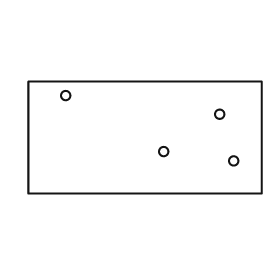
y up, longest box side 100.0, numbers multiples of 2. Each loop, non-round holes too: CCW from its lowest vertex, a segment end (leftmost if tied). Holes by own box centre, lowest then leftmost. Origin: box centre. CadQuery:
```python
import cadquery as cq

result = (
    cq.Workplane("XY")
    .moveTo(-50.0, -24.0)
    .lineTo(50.0, -24.0)
    .lineTo(50.0, 24.0)
    .lineTo(-50.0, 24.0)
    .close()
    .moveTo(38.0, -10.0)
    .circle(2.0)
    .moveTo(8.0, -6.0)
    .circle(2.0)
    .moveTo(32.0, 10.0)
    .circle(2.0)
    .moveTo(-34.0, 18.0)
    .circle(2.0)
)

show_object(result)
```